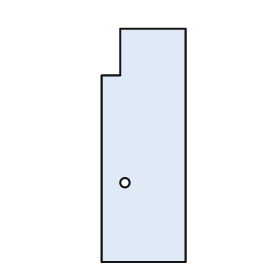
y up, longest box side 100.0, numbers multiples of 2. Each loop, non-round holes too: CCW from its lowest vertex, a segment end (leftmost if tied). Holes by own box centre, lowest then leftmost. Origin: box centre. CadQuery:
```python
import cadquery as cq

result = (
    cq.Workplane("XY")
    .moveTo(-18.0, -50.0)
    .lineTo(18.0, -50.0)
    .lineTo(18.0, 50.0)
    .lineTo(-10.0, 50.0)
    .lineTo(-10.0, 30.0)
    .lineTo(-18.0, 30.0)
    .close()
    .moveTo(-8.0, -16.0)
    .circle(2.0)
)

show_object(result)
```